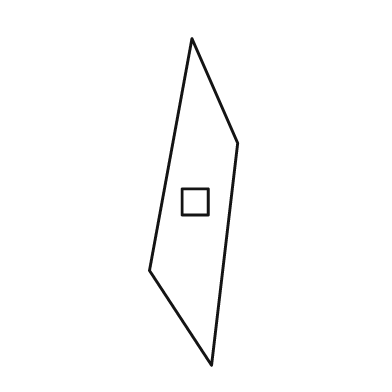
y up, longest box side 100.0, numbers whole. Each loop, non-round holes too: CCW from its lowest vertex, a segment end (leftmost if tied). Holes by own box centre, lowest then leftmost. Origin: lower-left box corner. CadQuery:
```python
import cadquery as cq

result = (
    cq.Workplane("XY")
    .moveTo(19.0, 0.0)
    .lineTo(27.0, 68.0)
    .lineTo(13.0, 100.0)
    .lineTo(0.0, 29.0)
    .close()
    .moveTo(10.0, 46.0)
    .lineTo(18.0, 46.0)
    .lineTo(18.0, 54.0)
    .lineTo(10.0, 54.0)
    .close()
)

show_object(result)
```